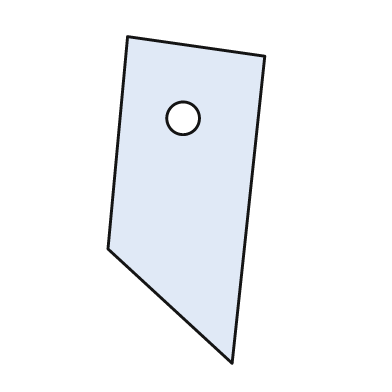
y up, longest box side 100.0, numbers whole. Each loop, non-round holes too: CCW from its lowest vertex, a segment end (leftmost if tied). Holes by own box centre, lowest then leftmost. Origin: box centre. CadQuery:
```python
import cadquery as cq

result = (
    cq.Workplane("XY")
    .moveTo(14.0, -50.0)
    .lineTo(24.0, 44.0)
    .lineTo(-18.0, 50.0)
    .lineTo(-24.0, -15.0)
    .close()
    .moveTo(-1.0, 25.0)
    .circle(5.0)
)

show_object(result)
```